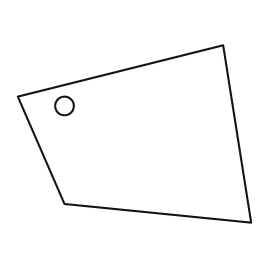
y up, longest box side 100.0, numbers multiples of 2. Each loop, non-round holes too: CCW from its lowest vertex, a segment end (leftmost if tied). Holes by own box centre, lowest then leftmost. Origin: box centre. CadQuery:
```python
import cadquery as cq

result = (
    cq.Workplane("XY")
    .moveTo(50.0, -38.0)
    .lineTo(38.0, 38.0)
    .lineTo(-50.0, 16.0)
    .lineTo(-30.0, -30.0)
    .close()
    .moveTo(-30.0, 12.0)
    .circle(4.0)
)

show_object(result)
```